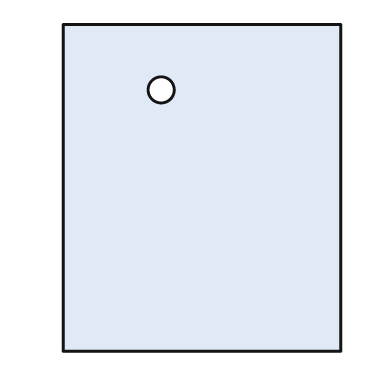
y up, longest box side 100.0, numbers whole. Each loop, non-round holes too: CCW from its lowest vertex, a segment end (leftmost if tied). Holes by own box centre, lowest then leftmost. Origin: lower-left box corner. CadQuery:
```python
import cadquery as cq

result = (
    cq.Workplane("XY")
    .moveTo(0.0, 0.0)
    .lineTo(85.0, 0.0)
    .lineTo(85.0, 100.0)
    .lineTo(0.0, 100.0)
    .close()
    .moveTo(30.0, 80.0)
    .circle(4.0)
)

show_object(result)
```